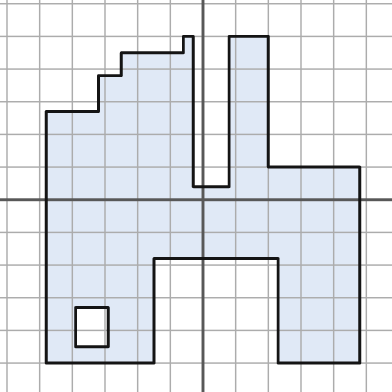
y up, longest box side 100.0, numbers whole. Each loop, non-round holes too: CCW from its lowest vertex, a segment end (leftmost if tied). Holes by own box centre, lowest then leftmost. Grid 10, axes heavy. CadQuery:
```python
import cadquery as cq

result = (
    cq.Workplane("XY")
    .moveTo(-48.0, -50.0)
    .lineTo(-15.0, -50.0)
    .lineTo(-15.0, -18.0)
    .lineTo(23.0, -18.0)
    .lineTo(23.0, -50.0)
    .lineTo(48.0, -50.0)
    .lineTo(48.0, 10.0)
    .lineTo(20.0, 10.0)
    .lineTo(20.0, 50.0)
    .lineTo(8.0, 50.0)
    .lineTo(8.0, 4.0)
    .lineTo(-3.0, 4.0)
    .lineTo(-3.0, 50.0)
    .lineTo(-6.0, 50.0)
    .lineTo(-6.0, 45.0)
    .lineTo(-25.0, 45.0)
    .lineTo(-25.0, 38.0)
    .lineTo(-32.0, 38.0)
    .lineTo(-32.0, 27.0)
    .lineTo(-48.0, 27.0)
    .close()
    .moveTo(-39.0, -45.0)
    .lineTo(-29.0, -45.0)
    .lineTo(-29.0, -33.0)
    .lineTo(-39.0, -33.0)
    .close()
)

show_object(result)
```